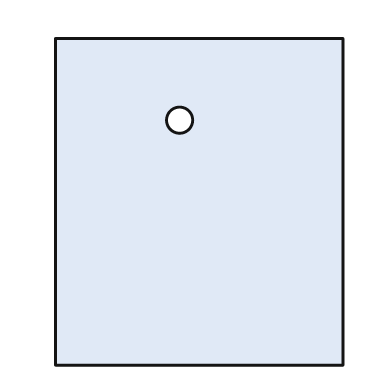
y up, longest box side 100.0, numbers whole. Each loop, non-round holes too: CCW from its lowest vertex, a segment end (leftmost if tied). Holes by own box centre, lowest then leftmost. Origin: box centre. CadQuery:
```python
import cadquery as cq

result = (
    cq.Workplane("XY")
    .moveTo(-44.0, -50.0)
    .lineTo(44.0, -50.0)
    .lineTo(44.0, 50.0)
    .lineTo(-44.0, 50.0)
    .close()
    .moveTo(-6.0, 25.0)
    .circle(4.0)
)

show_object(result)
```